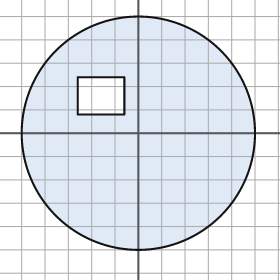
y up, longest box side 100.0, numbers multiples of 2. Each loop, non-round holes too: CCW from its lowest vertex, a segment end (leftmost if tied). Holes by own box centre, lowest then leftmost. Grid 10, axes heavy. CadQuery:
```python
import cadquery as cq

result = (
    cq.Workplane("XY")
    .moveTo(0.0, 0.0)
    .circle(50.0)
    .moveTo(-26.0, 8.0)
    .lineTo(-6.0, 8.0)
    .lineTo(-6.0, 24.0)
    .lineTo(-26.0, 24.0)
    .close()
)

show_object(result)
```